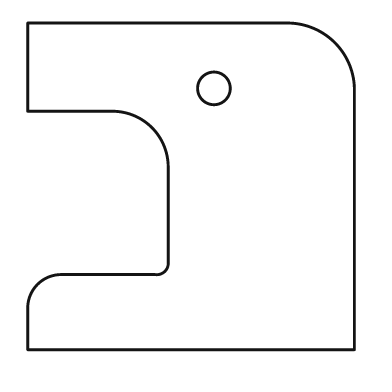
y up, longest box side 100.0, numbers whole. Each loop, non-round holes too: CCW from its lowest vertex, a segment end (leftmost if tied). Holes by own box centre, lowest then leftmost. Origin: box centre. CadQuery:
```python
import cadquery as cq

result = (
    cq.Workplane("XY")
    .moveTo(-50.0, -50.0)
    .lineTo(50.0, -50.0)
    .lineTo(50.0, 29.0)
    .threePointArc((44.0, 44.0), (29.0, 50.0))
    .lineTo(-50.0, 50.0)
    .lineTo(-50.0, 23.0)
    .lineTo(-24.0, 23.0)
    .threePointArc((-12.0, 18.0), (-7.0, 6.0))
    .lineTo(-7.0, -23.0)
    .threePointArc((-8.0, -26.0), (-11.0, -27.0))
    .lineTo(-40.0, -27.0)
    .threePointArc((-47.0, -30.0), (-50.0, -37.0))
    .close()
    .moveTo(7.0, 30.0)
    .circle(5.0)
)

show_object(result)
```